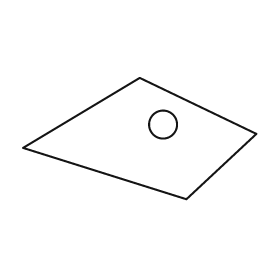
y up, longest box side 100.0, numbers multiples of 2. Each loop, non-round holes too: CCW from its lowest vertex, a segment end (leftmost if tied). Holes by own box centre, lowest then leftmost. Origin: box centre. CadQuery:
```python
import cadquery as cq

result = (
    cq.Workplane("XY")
    .moveTo(20.0, -26.0)
    .lineTo(50.0, 2.0)
    .lineTo(0.0, 26.0)
    .lineTo(-50.0, -4.0)
    .close()
    .moveTo(10.0, 6.0)
    .circle(6.0)
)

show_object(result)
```